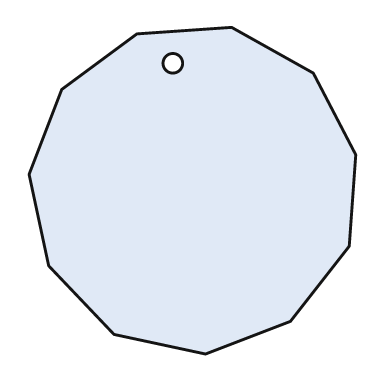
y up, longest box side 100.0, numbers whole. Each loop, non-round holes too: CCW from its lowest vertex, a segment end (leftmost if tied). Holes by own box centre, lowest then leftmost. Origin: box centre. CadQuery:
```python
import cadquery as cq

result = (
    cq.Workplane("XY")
    .moveTo(4.0, -50.0)
    .lineTo(30.0, -40.0)
    .lineTo(48.0, -17.0)
    .lineTo(50.0, 11.0)
    .lineTo(37.0, 36.0)
    .lineTo(12.0, 50.0)
    .lineTo(-17.0, 48.0)
    .lineTo(-40.0, 31.0)
    .lineTo(-50.0, 5.0)
    .lineTo(-44.0, -23.0)
    .lineTo(-24.0, -44.0)
    .close()
    .moveTo(-6.0, 39.0)
    .circle(3.0)
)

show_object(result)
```